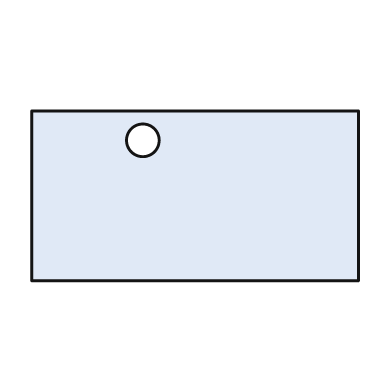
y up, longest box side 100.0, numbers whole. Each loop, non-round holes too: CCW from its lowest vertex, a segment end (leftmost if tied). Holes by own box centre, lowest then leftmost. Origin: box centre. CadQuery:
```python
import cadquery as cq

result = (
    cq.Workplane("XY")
    .moveTo(-50.0, -26.0)
    .lineTo(50.0, -26.0)
    .lineTo(50.0, 26.0)
    .lineTo(-50.0, 26.0)
    .close()
    .moveTo(-16.0, 17.0)
    .circle(5.0)
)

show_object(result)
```